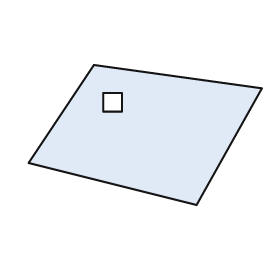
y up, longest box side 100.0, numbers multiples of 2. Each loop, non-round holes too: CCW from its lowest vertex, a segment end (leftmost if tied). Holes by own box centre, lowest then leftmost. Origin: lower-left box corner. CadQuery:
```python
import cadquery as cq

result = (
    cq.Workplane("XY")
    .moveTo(72.0, 0.0)
    .lineTo(100.0, 50.0)
    .lineTo(28.0, 60.0)
    .lineTo(0.0, 18.0)
    .close()
    .moveTo(32.0, 40.0)
    .lineTo(40.0, 40.0)
    .lineTo(40.0, 48.0)
    .lineTo(32.0, 48.0)
    .close()
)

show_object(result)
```